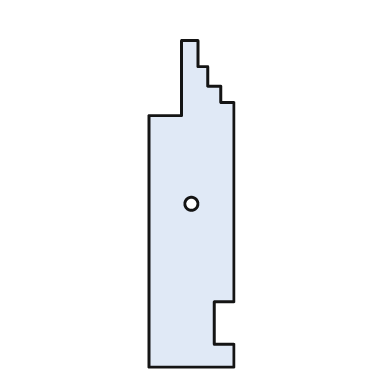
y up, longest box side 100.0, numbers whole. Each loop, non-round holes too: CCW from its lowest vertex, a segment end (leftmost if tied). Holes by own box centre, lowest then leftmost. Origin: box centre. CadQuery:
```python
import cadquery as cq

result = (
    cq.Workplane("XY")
    .moveTo(-13.0, -50.0)
    .lineTo(13.0, -50.0)
    .lineTo(13.0, -43.0)
    .lineTo(7.0, -43.0)
    .lineTo(7.0, -30.0)
    .lineTo(13.0, -30.0)
    .lineTo(13.0, 31.0)
    .lineTo(9.0, 31.0)
    .lineTo(9.0, 36.0)
    .lineTo(5.0, 36.0)
    .lineTo(5.0, 42.0)
    .lineTo(2.0, 42.0)
    .lineTo(2.0, 50.0)
    .lineTo(-3.0, 50.0)
    .lineTo(-3.0, 27.0)
    .lineTo(-13.0, 27.0)
    .close()
    .moveTo(0.0, 0.0)
    .circle(2.0)
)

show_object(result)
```